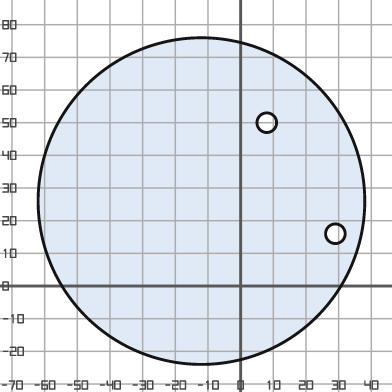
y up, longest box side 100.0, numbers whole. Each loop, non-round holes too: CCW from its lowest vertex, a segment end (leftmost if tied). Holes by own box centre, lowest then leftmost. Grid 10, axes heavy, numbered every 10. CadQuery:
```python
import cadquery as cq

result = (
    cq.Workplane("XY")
    .moveTo(-12.0, 26.0)
    .circle(50.0)
    .moveTo(29.0, 16.0)
    .circle(3.0)
    .moveTo(8.0, 50.0)
    .circle(3.0)
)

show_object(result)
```